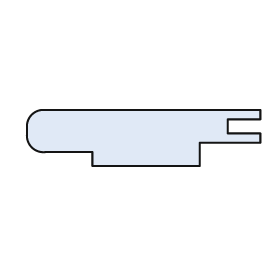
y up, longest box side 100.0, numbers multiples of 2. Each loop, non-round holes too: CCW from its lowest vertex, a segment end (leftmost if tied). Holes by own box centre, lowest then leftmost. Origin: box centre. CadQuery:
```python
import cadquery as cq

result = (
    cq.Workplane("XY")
    .moveTo(-22.0, -12.0)
    .lineTo(24.0, -12.0)
    .lineTo(24.0, -2.0)
    .lineTo(50.0, -2.0)
    .lineTo(50.0, 2.0)
    .lineTo(36.0, 2.0)
    .lineTo(36.0, 8.0)
    .lineTo(50.0, 8.0)
    .lineTo(50.0, 12.0)
    .lineTo(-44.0, 12.0)
    .threePointArc((-48.0, 10.0), (-50.0, 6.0))
    .lineTo(-50.0, 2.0)
    .threePointArc((-48.0, -4.0), (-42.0, -6.0))
    .lineTo(-22.0, -6.0)
    .close()
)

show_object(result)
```